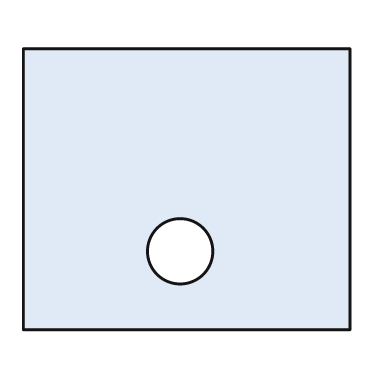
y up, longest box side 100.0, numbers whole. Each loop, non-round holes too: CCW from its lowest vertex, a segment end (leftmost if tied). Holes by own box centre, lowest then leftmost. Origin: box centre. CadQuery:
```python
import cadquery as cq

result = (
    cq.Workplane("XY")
    .moveTo(-50.0, -43.0)
    .lineTo(50.0, -43.0)
    .lineTo(50.0, 43.0)
    .lineTo(-50.0, 43.0)
    .close()
    .moveTo(-2.0, -19.0)
    .circle(10.0)
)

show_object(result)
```